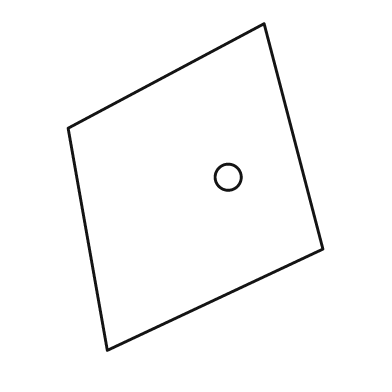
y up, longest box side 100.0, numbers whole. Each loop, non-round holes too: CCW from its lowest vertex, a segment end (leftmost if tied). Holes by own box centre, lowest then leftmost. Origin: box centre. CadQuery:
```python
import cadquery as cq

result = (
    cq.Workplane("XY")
    .moveTo(-27.0, -50.0)
    .lineTo(39.0, -19.0)
    .lineTo(21.0, 50.0)
    .lineTo(-39.0, 18.0)
    .close()
    .moveTo(10.0, 3.0)
    .circle(4.0)
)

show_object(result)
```